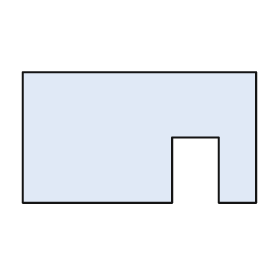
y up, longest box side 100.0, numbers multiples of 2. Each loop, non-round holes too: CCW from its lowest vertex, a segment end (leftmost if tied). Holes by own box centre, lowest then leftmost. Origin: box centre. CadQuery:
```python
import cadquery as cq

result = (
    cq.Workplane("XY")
    .moveTo(-50.0, -28.0)
    .lineTo(14.0, -28.0)
    .lineTo(14.0, 0.0)
    .lineTo(34.0, 0.0)
    .lineTo(34.0, -28.0)
    .lineTo(50.0, -28.0)
    .lineTo(50.0, 28.0)
    .lineTo(-50.0, 28.0)
    .close()
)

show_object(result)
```